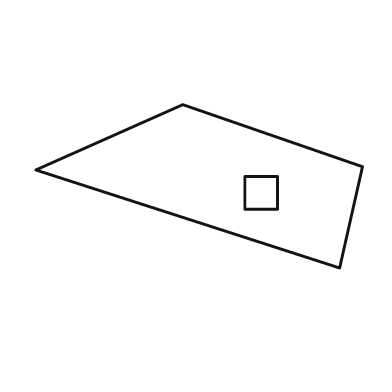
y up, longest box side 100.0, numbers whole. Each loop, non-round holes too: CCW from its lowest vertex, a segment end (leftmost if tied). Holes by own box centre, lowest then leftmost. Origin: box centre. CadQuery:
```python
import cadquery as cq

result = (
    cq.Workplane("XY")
    .moveTo(43.0, -25.0)
    .lineTo(50.0, 6.0)
    .lineTo(-5.0, 25.0)
    .lineTo(-50.0, 5.0)
    .close()
    .moveTo(14.0, -7.0)
    .lineTo(24.0, -7.0)
    .lineTo(24.0, 3.0)
    .lineTo(14.0, 3.0)
    .close()
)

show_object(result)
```